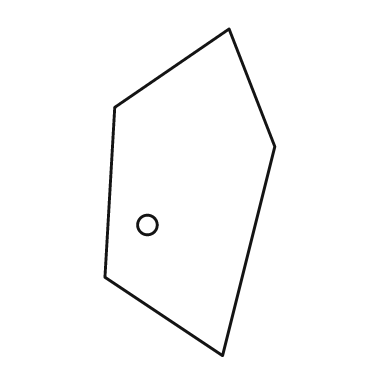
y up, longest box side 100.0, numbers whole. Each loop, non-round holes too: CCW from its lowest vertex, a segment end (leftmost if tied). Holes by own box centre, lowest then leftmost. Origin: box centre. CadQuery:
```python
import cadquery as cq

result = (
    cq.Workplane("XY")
    .moveTo(10.0, -50.0)
    .lineTo(26.0, 14.0)
    .lineTo(12.0, 50.0)
    .lineTo(-23.0, 26.0)
    .lineTo(-26.0, -26.0)
    .close()
    .moveTo(-13.0, -10.0)
    .circle(3.0)
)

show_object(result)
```